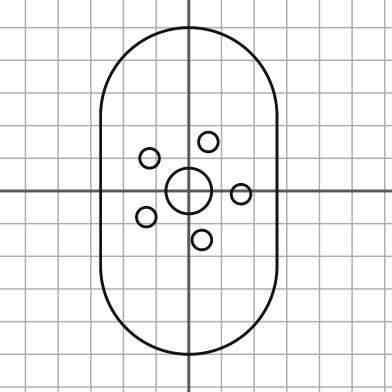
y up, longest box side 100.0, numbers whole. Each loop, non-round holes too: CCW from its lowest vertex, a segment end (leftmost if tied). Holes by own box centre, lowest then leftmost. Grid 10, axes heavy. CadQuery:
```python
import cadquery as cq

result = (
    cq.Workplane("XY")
    .moveTo(-27.0, -23.0)
    .threePointArc((0.0, -50.0), (27.0, -23.0))
    .lineTo(27.0, 23.0)
    .threePointArc((0.0, 50.0), (-27.0, 23.0))
    .close()
    .moveTo(4.0, -15.0)
    .circle(3.0)
    .moveTo(-13.0, -8.0)
    .circle(3.0)
    .moveTo(16.0, -1.0)
    .circle(3.0)
    .moveTo(0.0, 0.0)
    .circle(7.0)
    .moveTo(-12.0, 10.0)
    .circle(3.0)
    .moveTo(6.0, 15.0)
    .circle(3.0)
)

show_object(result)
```